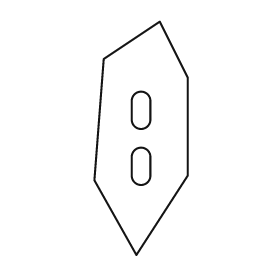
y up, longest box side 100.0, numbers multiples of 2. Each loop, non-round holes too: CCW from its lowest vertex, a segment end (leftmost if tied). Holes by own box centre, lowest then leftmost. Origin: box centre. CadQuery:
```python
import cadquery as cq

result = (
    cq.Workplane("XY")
    .moveTo(-2.0, -50.0)
    .lineTo(20.0, -16.0)
    .lineTo(20.0, 26.0)
    .lineTo(8.0, 50.0)
    .lineTo(-16.0, 34.0)
    .lineTo(-20.0, -18.0)
    .close()
    .moveTo(-4.0, -16.0)
    .threePointArc((0.0, -20.0), (4.0, -16.0))
    .lineTo(4.0, -8.0)
    .threePointArc((0.0, -4.0), (-4.0, -8.0))
    .close()
    .moveTo(-4.0, 8.0)
    .threePointArc((0.0, 4.0), (4.0, 8.0))
    .lineTo(4.0, 16.0)
    .threePointArc((0.0, 20.0), (-4.0, 16.0))
    .close()
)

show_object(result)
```